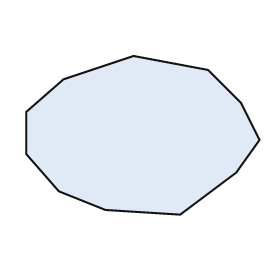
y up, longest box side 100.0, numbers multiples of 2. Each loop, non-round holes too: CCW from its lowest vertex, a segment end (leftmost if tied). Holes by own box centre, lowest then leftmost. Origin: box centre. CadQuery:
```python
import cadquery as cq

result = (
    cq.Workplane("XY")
    .moveTo(16.0, -34.0)
    .lineTo(40.0, -16.0)
    .lineTo(50.0, -2.0)
    .lineTo(42.0, 14.0)
    .lineTo(28.0, 28.0)
    .lineTo(-4.0, 34.0)
    .lineTo(-34.0, 24.0)
    .lineTo(-50.0, 10.0)
    .lineTo(-50.0, -8.0)
    .lineTo(-36.0, -24.0)
    .lineTo(-16.0, -32.0)
    .close()
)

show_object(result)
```